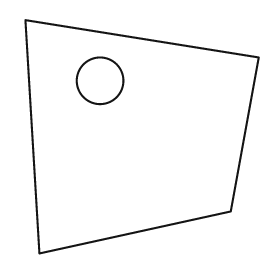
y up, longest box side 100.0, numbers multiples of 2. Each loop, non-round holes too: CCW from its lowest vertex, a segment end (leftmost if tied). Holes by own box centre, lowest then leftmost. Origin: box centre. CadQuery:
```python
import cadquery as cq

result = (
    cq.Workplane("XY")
    .moveTo(-44.0, -50.0)
    .lineTo(38.0, -32.0)
    .lineTo(50.0, 34.0)
    .lineTo(-50.0, 50.0)
    .close()
    .moveTo(-18.0, 24.0)
    .circle(10.0)
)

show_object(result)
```